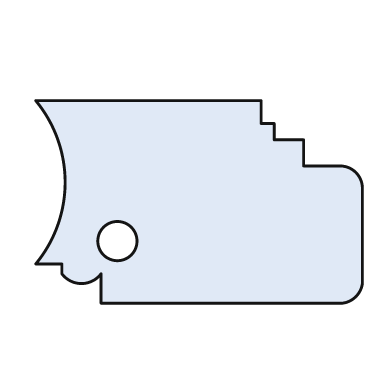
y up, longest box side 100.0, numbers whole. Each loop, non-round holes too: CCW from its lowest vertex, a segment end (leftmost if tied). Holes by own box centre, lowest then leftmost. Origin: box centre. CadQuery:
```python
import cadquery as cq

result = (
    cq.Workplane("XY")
    .moveTo(-30.0, -31.0)
    .lineTo(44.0, -31.0)
    .threePointArc((48.0, -29.0), (50.0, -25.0))
    .lineTo(50.0, 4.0)
    .threePointArc((48.0, 9.0), (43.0, 11.0))
    .lineTo(32.0, 11.0)
    .lineTo(32.0, 19.0)
    .lineTo(23.0, 19.0)
    .lineTo(23.0, 24.0)
    .lineTo(19.0, 24.0)
    .lineTo(19.0, 31.0)
    .lineTo(-50.0, 31.0)
    .threePointArc((-41.0, 6.0), (-50.0, -19.0))
    .lineTo(-42.0, -19.0)
    .lineTo(-42.0, -22.0)
    .threePointArc((-36.0, -25.0), (-30.0, -22.0))
    .close()
    .moveTo(-25.0, -12.0)
    .circle(6.0)
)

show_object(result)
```